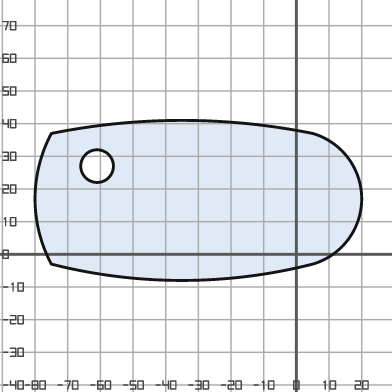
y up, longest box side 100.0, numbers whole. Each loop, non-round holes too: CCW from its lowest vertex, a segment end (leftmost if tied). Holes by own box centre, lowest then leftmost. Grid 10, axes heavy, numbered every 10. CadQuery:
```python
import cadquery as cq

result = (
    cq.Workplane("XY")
    .moveTo(-75.0, -3.0)
    .threePointArc((-35.0, -8.0), (5.0, -3.0))
    .threePointArc((20.0, 17.0), (5.0, 37.0))
    .threePointArc((-35.0, 41.0), (-75.0, 37.0))
    .threePointArc((-80.0, 17.0), (-75.0, -3.0))
    .close()
    .moveTo(-61.0, 27.0)
    .circle(5.0)
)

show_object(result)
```